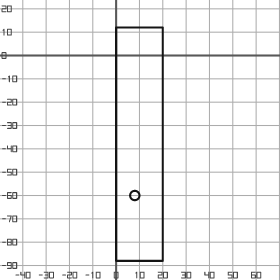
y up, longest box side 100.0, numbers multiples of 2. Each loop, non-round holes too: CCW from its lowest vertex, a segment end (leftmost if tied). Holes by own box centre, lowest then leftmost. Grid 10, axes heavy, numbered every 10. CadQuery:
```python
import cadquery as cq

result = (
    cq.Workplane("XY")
    .moveTo(0.0, -88.0)
    .lineTo(20.0, -88.0)
    .lineTo(20.0, 12.0)
    .lineTo(0.0, 12.0)
    .close()
    .moveTo(8.0, -60.0)
    .circle(2.0)
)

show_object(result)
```